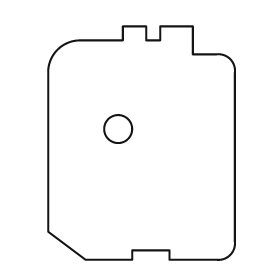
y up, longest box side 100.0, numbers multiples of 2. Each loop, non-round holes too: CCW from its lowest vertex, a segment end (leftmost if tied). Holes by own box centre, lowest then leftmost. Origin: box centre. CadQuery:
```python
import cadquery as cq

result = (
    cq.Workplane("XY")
    .moveTo(-24.0, -50.0)
    .lineTo(-4.0, -50.0)
    .lineTo(-4.0, -46.0)
    .lineTo(12.0, -46.0)
    .lineTo(12.0, -50.0)
    .lineTo(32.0, -50.0)
    .threePointArc((38.0, -48.0), (40.0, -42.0))
    .lineTo(40.0, 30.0)
    .threePointArc((38.0, 36.0), (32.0, 38.0))
    .lineTo(22.0, 38.0)
    .lineTo(22.0, 50.0)
    .lineTo(8.0, 50.0)
    .lineTo(8.0, 44.0)
    .lineTo(2.0, 44.0)
    .lineTo(2.0, 50.0)
    .lineTo(-8.0, 50.0)
    .lineTo(-8.0, 44.0)
    .lineTo(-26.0, 44.0)
    .threePointArc((-36.0, 40.0), (-40.0, 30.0))
    .lineTo(-40.0, -38.0)
    .close()
    .moveTo(-10.0, 6.0)
    .circle(6.0)
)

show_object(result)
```